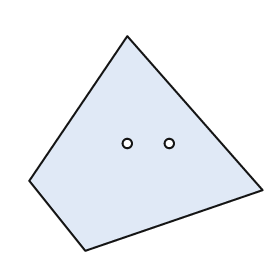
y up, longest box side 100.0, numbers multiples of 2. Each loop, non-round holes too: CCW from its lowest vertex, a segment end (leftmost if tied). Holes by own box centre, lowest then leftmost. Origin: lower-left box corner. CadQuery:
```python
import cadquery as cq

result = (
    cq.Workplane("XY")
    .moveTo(24.0, 0.0)
    .lineTo(100.0, 26.0)
    .lineTo(42.0, 92.0)
    .lineTo(0.0, 30.0)
    .close()
    .moveTo(42.0, 46.0)
    .circle(2.0)
    .moveTo(60.0, 46.0)
    .circle(2.0)
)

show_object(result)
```